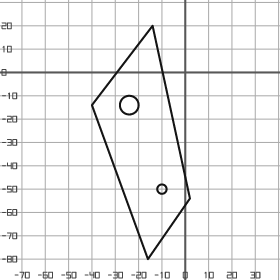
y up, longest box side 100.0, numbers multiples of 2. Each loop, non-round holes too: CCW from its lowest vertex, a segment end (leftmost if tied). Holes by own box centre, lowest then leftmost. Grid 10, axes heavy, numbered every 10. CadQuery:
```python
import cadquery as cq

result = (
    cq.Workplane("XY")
    .moveTo(-16.0, -80.0)
    .lineTo(2.0, -54.0)
    .lineTo(-14.0, 20.0)
    .lineTo(-40.0, -14.0)
    .close()
    .moveTo(-10.0, -50.0)
    .circle(2.0)
    .moveTo(-24.0, -14.0)
    .circle(4.0)
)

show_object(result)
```